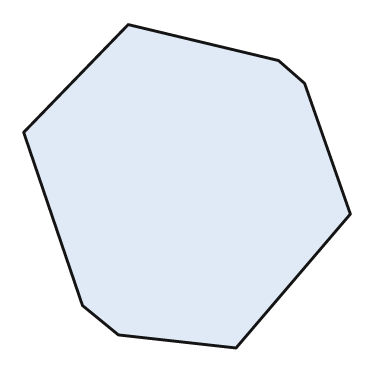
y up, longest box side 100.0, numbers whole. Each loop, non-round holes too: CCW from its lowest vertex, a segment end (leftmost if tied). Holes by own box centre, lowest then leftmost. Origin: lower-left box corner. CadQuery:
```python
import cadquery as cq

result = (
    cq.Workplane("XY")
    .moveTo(65.0, 0.0)
    .lineTo(100.0, 41.0)
    .lineTo(86.0, 81.0)
    .lineTo(78.0, 88.0)
    .lineTo(32.0, 99.0)
    .lineTo(0.0, 66.0)
    .lineTo(18.0, 13.0)
    .lineTo(29.0, 4.0)
    .close()
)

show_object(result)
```